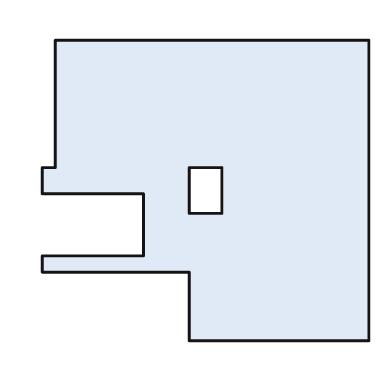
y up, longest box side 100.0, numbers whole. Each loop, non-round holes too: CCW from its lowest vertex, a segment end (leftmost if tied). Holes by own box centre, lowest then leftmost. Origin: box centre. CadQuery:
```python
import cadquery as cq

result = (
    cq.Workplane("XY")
    .moveTo(-5.0, -46.0)
    .lineTo(50.0, -46.0)
    .lineTo(50.0, 46.0)
    .lineTo(-46.0, 46.0)
    .lineTo(-46.0, 7.0)
    .lineTo(-50.0, 7.0)
    .lineTo(-50.0, -1.0)
    .lineTo(-19.0, -1.0)
    .lineTo(-19.0, -20.0)
    .lineTo(-50.0, -20.0)
    .lineTo(-50.0, -25.0)
    .lineTo(-5.0, -25.0)
    .close()
    .moveTo(-5.0, -7.0)
    .lineTo(5.0, -7.0)
    .lineTo(5.0, 7.0)
    .lineTo(-5.0, 7.0)
    .close()
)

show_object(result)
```